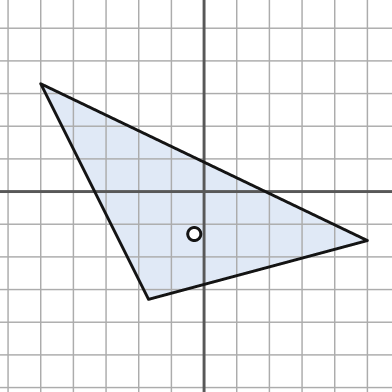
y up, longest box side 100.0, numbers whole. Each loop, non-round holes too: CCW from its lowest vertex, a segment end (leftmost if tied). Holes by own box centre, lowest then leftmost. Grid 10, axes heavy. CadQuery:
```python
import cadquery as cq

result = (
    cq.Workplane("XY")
    .moveTo(-17.0, -33.0)
    .lineTo(50.0, -15.0)
    .lineTo(-50.0, 33.0)
    .close()
    .moveTo(-3.0, -13.0)
    .circle(2.0)
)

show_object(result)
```